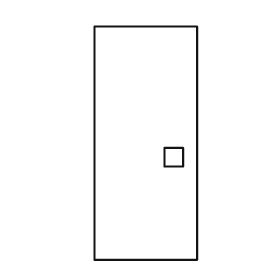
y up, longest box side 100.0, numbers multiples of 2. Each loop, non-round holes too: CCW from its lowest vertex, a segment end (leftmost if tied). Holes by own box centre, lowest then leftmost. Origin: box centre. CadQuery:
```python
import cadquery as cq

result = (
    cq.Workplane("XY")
    .moveTo(-22.0, -50.0)
    .lineTo(22.0, -50.0)
    .lineTo(22.0, 50.0)
    .lineTo(-22.0, 50.0)
    .close()
    .moveTo(8.0, -10.0)
    .lineTo(16.0, -10.0)
    .lineTo(16.0, -2.0)
    .lineTo(8.0, -2.0)
    .close()
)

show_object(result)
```